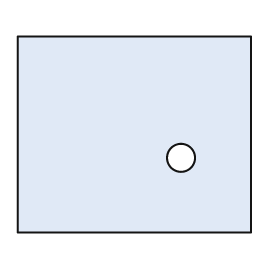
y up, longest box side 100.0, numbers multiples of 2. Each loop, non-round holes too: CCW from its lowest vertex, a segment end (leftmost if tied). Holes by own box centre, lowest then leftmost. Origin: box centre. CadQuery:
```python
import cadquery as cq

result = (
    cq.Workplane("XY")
    .moveTo(-50.0, -42.0)
    .lineTo(50.0, -42.0)
    .lineTo(50.0, 42.0)
    .lineTo(-50.0, 42.0)
    .close()
    .moveTo(20.0, -10.0)
    .circle(6.0)
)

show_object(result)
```